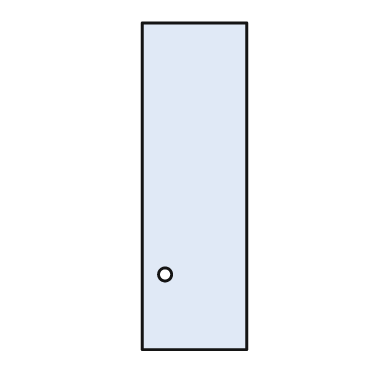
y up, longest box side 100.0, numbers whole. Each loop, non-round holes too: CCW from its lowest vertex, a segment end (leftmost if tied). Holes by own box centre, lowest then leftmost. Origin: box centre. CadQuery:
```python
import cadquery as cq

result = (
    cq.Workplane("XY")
    .moveTo(-16.0, -50.0)
    .lineTo(16.0, -50.0)
    .lineTo(16.0, 50.0)
    .lineTo(-16.0, 50.0)
    .close()
    .moveTo(-9.0, -27.0)
    .circle(2.0)
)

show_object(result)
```